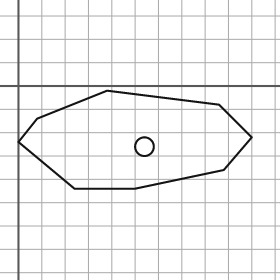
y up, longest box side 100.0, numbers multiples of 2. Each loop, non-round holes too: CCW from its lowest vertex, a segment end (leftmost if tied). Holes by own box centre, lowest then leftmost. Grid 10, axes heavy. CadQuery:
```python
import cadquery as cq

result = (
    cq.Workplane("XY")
    .moveTo(24.0, -44.0)
    .lineTo(50.0, -44.0)
    .lineTo(88.0, -36.0)
    .lineTo(100.0, -22.0)
    .lineTo(86.0, -8.0)
    .lineTo(38.0, -2.0)
    .lineTo(8.0, -14.0)
    .lineTo(0.0, -24.0)
    .close()
    .moveTo(54.0, -26.0)
    .circle(4.0)
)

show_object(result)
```